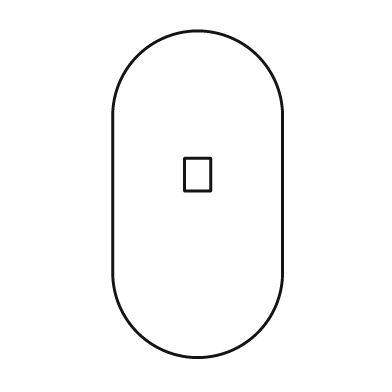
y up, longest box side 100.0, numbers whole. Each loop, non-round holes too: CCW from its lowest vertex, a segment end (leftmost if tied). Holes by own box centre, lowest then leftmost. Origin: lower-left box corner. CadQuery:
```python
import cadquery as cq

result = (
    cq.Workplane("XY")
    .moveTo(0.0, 26.0)
    .threePointArc((26.0, 0.0), (52.0, 26.0))
    .lineTo(52.0, 74.0)
    .threePointArc((26.0, 100.0), (0.0, 74.0))
    .close()
    .moveTo(22.0, 51.0)
    .lineTo(30.0, 51.0)
    .lineTo(30.0, 61.0)
    .lineTo(22.0, 61.0)
    .close()
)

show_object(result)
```